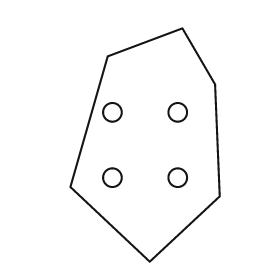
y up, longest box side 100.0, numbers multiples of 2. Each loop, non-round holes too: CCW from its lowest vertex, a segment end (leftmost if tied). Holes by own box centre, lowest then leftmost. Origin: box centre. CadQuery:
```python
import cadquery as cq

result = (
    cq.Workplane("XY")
    .moveTo(2.0, -50.0)
    .lineTo(32.0, -22.0)
    .lineTo(30.0, 26.0)
    .lineTo(16.0, 50.0)
    .lineTo(-16.0, 38.0)
    .lineTo(-32.0, -18.0)
    .close()
    .moveTo(-14.0, -14.0)
    .circle(4.0)
    .moveTo(14.0, -14.0)
    .circle(4.0)
    .moveTo(-14.0, 14.0)
    .circle(4.0)
    .moveTo(14.0, 14.0)
    .circle(4.0)
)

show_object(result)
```